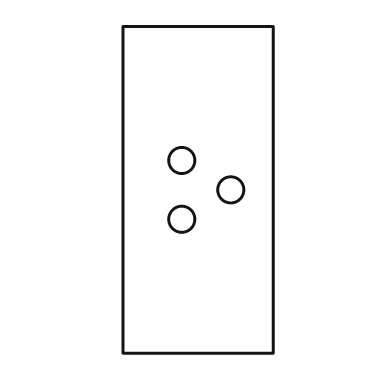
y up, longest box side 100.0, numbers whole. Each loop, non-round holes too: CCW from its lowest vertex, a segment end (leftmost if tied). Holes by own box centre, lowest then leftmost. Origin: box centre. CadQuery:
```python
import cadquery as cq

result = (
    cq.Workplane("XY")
    .moveTo(-23.0, -50.0)
    .lineTo(23.0, -50.0)
    .lineTo(23.0, 50.0)
    .lineTo(-23.0, 50.0)
    .close()
    .moveTo(-5.0, -9.0)
    .circle(4.0)
    .moveTo(10.0, 0.0)
    .circle(4.0)
    .moveTo(-5.0, 9.0)
    .circle(4.0)
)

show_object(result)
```